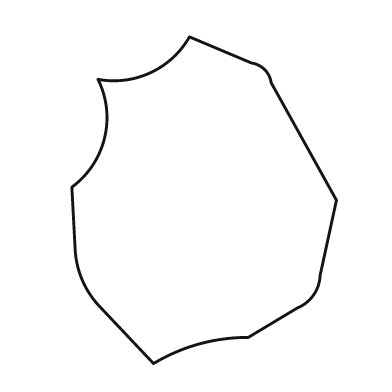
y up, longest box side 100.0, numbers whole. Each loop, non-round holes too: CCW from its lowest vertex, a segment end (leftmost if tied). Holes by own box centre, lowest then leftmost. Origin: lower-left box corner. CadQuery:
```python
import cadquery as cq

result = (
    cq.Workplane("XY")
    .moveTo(25.0, 0.0)
    .threePointArc((39.0, 6.0), (54.0, 8.0))
    .lineTo(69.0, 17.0)
    .threePointArc((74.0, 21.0), (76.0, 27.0))
    .lineTo(81.0, 50.0)
    .lineTo(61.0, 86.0)
    .threePointArc((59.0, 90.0), (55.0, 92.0))
    .lineTo(36.0, 100.0)
    .threePointArc((24.0, 89.0), (8.0, 87.0))
    .threePointArc((10.0, 69.0), (0.0, 54.0))
    .lineTo(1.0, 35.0)
    .threePointArc((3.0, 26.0), (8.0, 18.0))
    .close()
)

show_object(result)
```